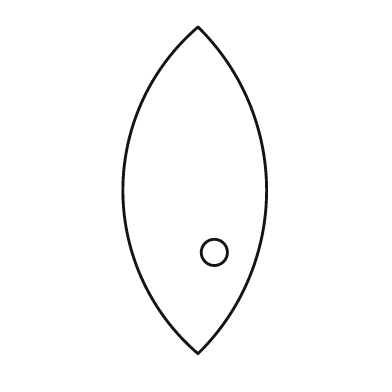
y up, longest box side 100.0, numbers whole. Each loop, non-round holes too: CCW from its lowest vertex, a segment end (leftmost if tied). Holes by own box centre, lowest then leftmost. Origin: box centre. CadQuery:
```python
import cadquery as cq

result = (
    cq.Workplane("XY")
    .moveTo(1.0, -50.0)
    .threePointArc((22.0, 0.0), (1.0, 50.0))
    .threePointArc((-22.0, 0.0), (1.0, -50.0))
    .close()
    .moveTo(6.0, -19.0)
    .circle(4.0)
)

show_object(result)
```